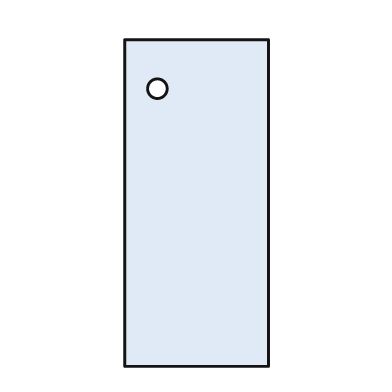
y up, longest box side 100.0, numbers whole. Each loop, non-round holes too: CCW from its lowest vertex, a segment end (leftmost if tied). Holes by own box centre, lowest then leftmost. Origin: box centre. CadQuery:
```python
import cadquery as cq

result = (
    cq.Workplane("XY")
    .moveTo(-22.0, -50.0)
    .lineTo(22.0, -50.0)
    .lineTo(22.0, 50.0)
    .lineTo(-22.0, 50.0)
    .close()
    .moveTo(-12.0, 35.0)
    .circle(3.0)
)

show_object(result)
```